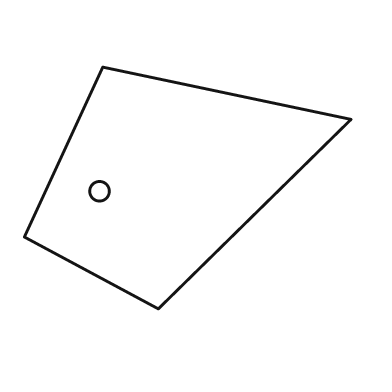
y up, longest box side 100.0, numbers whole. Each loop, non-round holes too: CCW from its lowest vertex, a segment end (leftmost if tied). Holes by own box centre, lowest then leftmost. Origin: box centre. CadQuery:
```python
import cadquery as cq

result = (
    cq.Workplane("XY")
    .moveTo(-9.0, -37.0)
    .lineTo(50.0, 21.0)
    .lineTo(-26.0, 37.0)
    .lineTo(-50.0, -15.0)
    .close()
    .moveTo(-27.0, -1.0)
    .circle(3.0)
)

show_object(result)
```